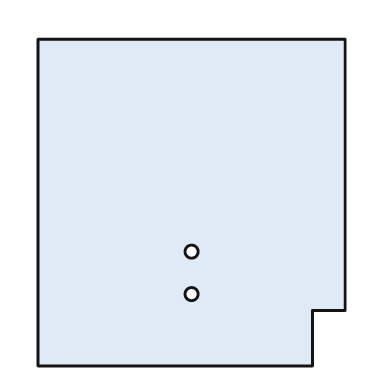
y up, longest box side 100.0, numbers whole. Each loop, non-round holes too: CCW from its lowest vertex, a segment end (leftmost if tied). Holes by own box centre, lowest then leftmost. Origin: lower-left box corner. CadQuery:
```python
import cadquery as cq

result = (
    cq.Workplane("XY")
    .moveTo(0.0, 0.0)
    .lineTo(84.0, 0.0)
    .lineTo(84.0, 17.0)
    .lineTo(94.0, 17.0)
    .lineTo(94.0, 100.0)
    .lineTo(0.0, 100.0)
    .close()
    .moveTo(47.0, 22.0)
    .circle(2.0)
    .moveTo(47.0, 35.0)
    .circle(2.0)
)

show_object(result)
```